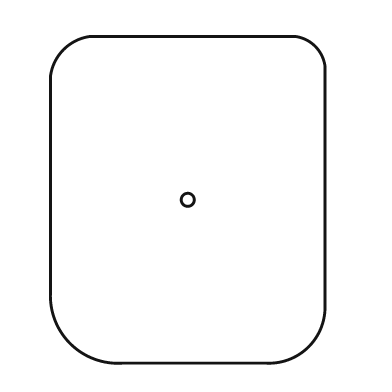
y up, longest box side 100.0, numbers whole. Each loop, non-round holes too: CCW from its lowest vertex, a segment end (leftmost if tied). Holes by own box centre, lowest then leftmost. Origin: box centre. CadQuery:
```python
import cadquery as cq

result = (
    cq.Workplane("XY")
    .moveTo(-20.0, -50.0)
    .lineTo(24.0, -50.0)
    .threePointArc((37.0, -45.0), (42.0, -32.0))
    .lineTo(42.0, 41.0)
    .threePointArc((39.0, 47.0), (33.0, 50.0))
    .lineTo(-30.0, 50.0)
    .threePointArc((-38.0, 46.0), (-42.0, 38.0))
    .lineTo(-42.0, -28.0)
    .threePointArc((-36.0, -44.0), (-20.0, -50.0))
    .close()
    .moveTo(0.0, 0.0)
    .circle(2.0)
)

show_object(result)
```